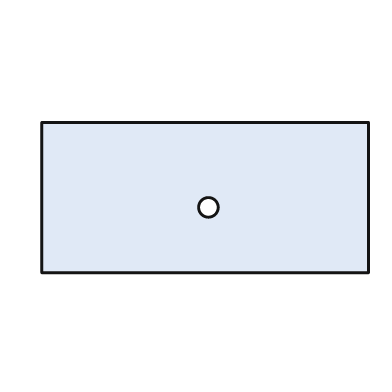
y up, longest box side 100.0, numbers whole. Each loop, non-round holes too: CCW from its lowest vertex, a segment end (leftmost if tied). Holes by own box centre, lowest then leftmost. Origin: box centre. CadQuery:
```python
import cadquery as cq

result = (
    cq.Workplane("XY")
    .moveTo(-50.0, -23.0)
    .lineTo(50.0, -23.0)
    .lineTo(50.0, 23.0)
    .lineTo(-50.0, 23.0)
    .close()
    .moveTo(1.0, -3.0)
    .circle(3.0)
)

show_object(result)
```